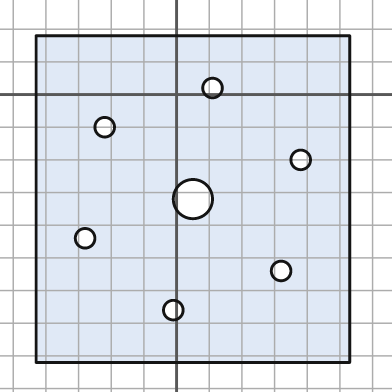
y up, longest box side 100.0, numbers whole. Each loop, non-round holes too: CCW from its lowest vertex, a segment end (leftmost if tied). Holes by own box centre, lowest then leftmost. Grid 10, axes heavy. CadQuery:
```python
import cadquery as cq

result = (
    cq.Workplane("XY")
    .moveTo(-43.0, -82.0)
    .lineTo(53.0, -82.0)
    .lineTo(53.0, 18.0)
    .lineTo(-43.0, 18.0)
    .close()
    .moveTo(-1.0, -66.0)
    .circle(3.0)
    .moveTo(32.0, -54.0)
    .circle(3.0)
    .moveTo(-28.0, -44.0)
    .circle(3.0)
    .moveTo(5.0, -32.0)
    .circle(6.0)
    .moveTo(38.0, -20.0)
    .circle(3.0)
    .moveTo(-22.0, -10.0)
    .circle(3.0)
    .moveTo(11.0, 2.0)
    .circle(3.0)
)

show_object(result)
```